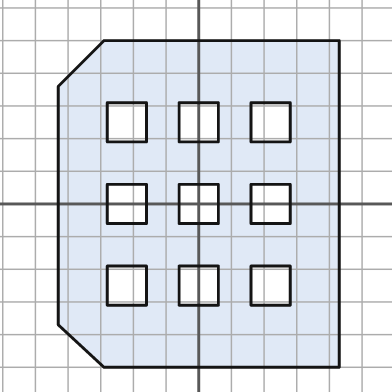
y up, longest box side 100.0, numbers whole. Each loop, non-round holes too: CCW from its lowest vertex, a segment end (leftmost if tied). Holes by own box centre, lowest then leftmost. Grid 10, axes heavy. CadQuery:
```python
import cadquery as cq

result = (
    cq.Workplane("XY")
    .moveTo(-29.0, -50.0)
    .lineTo(43.0, -50.0)
    .lineTo(43.0, 50.0)
    .lineTo(-29.0, 50.0)
    .lineTo(-43.0, 36.0)
    .lineTo(-43.0, -37.0)
    .close()
    .moveTo(-28.0, -31.0)
    .lineTo(-16.0, -31.0)
    .lineTo(-16.0, -19.0)
    .lineTo(-28.0, -19.0)
    .close()
    .moveTo(-6.0, -31.0)
    .lineTo(6.0, -31.0)
    .lineTo(6.0, -19.0)
    .lineTo(-6.0, -19.0)
    .close()
    .moveTo(16.0, -31.0)
    .lineTo(28.0, -31.0)
    .lineTo(28.0, -19.0)
    .lineTo(16.0, -19.0)
    .close()
    .moveTo(-28.0, -6.0)
    .lineTo(-16.0, -6.0)
    .lineTo(-16.0, 6.0)
    .lineTo(-28.0, 6.0)
    .close()
    .moveTo(-6.0, -6.0)
    .lineTo(6.0, -6.0)
    .lineTo(6.0, 6.0)
    .lineTo(-6.0, 6.0)
    .close()
    .moveTo(16.0, -6.0)
    .lineTo(28.0, -6.0)
    .lineTo(28.0, 6.0)
    .lineTo(16.0, 6.0)
    .close()
    .moveTo(-28.0, 19.0)
    .lineTo(-16.0, 19.0)
    .lineTo(-16.0, 31.0)
    .lineTo(-28.0, 31.0)
    .close()
    .moveTo(-6.0, 19.0)
    .lineTo(6.0, 19.0)
    .lineTo(6.0, 31.0)
    .lineTo(-6.0, 31.0)
    .close()
    .moveTo(16.0, 19.0)
    .lineTo(28.0, 19.0)
    .lineTo(28.0, 31.0)
    .lineTo(16.0, 31.0)
    .close()
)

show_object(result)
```